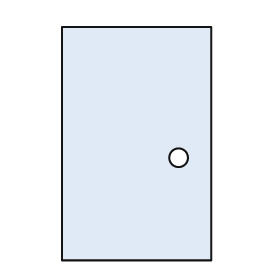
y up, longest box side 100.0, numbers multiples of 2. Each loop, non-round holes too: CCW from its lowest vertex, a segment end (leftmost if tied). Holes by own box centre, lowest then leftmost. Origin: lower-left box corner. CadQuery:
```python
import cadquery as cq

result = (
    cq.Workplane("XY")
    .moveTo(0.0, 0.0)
    .lineTo(64.0, 0.0)
    .lineTo(64.0, 100.0)
    .lineTo(0.0, 100.0)
    .close()
    .moveTo(50.0, 44.0)
    .circle(4.0)
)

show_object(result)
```